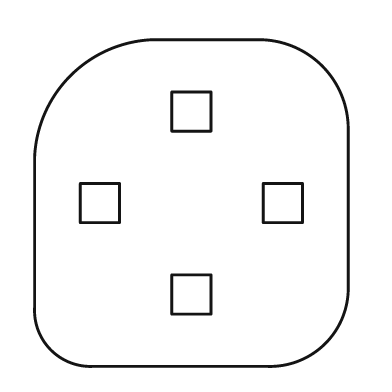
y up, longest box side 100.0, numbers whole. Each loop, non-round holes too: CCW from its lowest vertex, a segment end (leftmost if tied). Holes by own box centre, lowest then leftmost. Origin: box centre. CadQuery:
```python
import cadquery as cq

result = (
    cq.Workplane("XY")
    .moveTo(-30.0, -50.0)
    .lineTo(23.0, -50.0)
    .threePointArc((41.0, -43.0), (48.0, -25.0))
    .lineTo(48.0, 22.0)
    .threePointArc((40.0, 42.0), (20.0, 50.0))
    .lineTo(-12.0, 50.0)
    .threePointArc((-37.0, 39.0), (-48.0, 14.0))
    .lineTo(-48.0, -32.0)
    .threePointArc((-43.0, -45.0), (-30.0, -50.0))
    .close()
    .moveTo(-6.0, -34.0)
    .lineTo(6.0, -34.0)
    .lineTo(6.0, -22.0)
    .lineTo(-6.0, -22.0)
    .close()
    .moveTo(-34.0, -6.0)
    .lineTo(-22.0, -6.0)
    .lineTo(-22.0, 6.0)
    .lineTo(-34.0, 6.0)
    .close()
    .moveTo(22.0, -6.0)
    .lineTo(34.0, -6.0)
    .lineTo(34.0, 6.0)
    .lineTo(22.0, 6.0)
    .close()
    .moveTo(-6.0, 22.0)
    .lineTo(6.0, 22.0)
    .lineTo(6.0, 34.0)
    .lineTo(-6.0, 34.0)
    .close()
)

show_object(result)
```